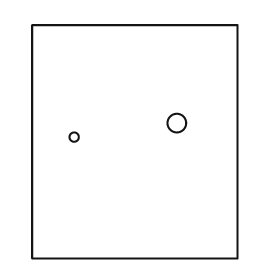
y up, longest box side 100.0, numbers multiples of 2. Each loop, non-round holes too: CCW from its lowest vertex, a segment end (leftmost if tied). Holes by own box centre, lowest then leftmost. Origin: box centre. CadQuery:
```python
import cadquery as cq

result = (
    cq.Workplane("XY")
    .moveTo(-44.0, -50.0)
    .lineTo(44.0, -50.0)
    .lineTo(44.0, 50.0)
    .lineTo(-44.0, 50.0)
    .close()
    .moveTo(-26.0, 2.0)
    .circle(2.0)
    .moveTo(18.0, 8.0)
    .circle(4.0)
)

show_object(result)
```